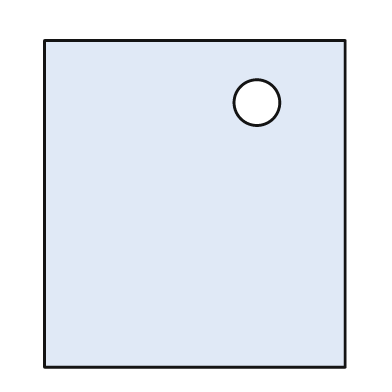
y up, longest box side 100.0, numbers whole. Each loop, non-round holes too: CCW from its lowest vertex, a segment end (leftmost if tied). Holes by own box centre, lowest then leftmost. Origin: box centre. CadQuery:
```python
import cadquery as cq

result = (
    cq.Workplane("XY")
    .moveTo(-46.0, -50.0)
    .lineTo(46.0, -50.0)
    .lineTo(46.0, 50.0)
    .lineTo(-46.0, 50.0)
    .close()
    .moveTo(19.0, 31.0)
    .circle(7.0)
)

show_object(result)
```